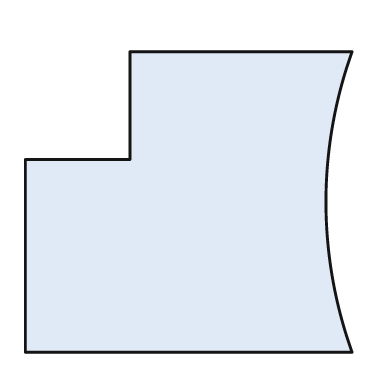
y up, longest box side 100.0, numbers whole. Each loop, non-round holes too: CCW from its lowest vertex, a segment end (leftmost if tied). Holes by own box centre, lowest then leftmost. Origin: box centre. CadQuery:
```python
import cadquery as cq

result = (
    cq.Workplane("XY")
    .moveTo(-50.0, -46.0)
    .lineTo(50.0, -46.0)
    .threePointArc((42.0, 0.0), (50.0, 46.0))
    .lineTo(-18.0, 46.0)
    .lineTo(-18.0, 13.0)
    .lineTo(-50.0, 13.0)
    .close()
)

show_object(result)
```